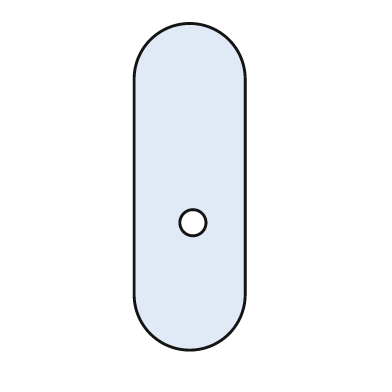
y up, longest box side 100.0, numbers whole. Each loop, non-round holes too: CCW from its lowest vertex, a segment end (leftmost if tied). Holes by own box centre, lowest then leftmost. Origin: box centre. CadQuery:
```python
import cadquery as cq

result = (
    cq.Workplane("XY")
    .moveTo(-17.0, -33.0)
    .threePointArc((0.0, -50.0), (17.0, -33.0))
    .lineTo(17.0, 33.0)
    .threePointArc((0.0, 50.0), (-17.0, 33.0))
    .close()
    .moveTo(1.0, -11.0)
    .circle(4.0)
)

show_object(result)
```